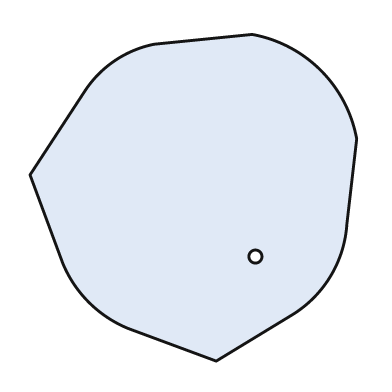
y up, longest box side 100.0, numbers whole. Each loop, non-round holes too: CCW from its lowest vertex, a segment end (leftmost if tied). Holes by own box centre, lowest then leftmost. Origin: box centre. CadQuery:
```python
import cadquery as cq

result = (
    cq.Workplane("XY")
    .moveTo(7.0, -50.0)
    .lineTo(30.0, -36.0)
    .threePointArc((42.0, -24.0), (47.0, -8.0))
    .lineTo(50.0, 18.0)
    .threePointArc((39.0, 39.0), (18.0, 50.0))
    .lineTo(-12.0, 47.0)
    .threePointArc((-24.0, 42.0), (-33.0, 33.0))
    .lineTo(-50.0, 7.0)
    .lineTo(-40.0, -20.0)
    .threePointArc((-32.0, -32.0), (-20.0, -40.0))
    .close()
    .moveTo(19.0, -18.0)
    .circle(2.0)
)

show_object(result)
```